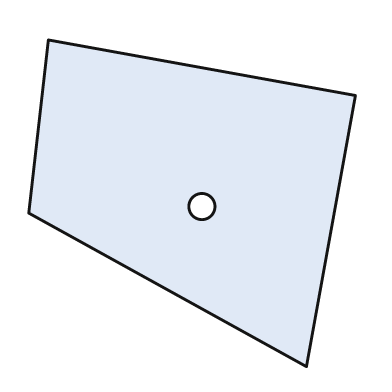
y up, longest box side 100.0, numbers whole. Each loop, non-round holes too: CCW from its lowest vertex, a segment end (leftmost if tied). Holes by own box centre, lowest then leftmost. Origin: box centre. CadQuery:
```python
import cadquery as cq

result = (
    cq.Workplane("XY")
    .moveTo(35.0, -50.0)
    .lineTo(50.0, 33.0)
    .lineTo(-44.0, 50.0)
    .lineTo(-50.0, -3.0)
    .close()
    .moveTo(3.0, -1.0)
    .circle(4.0)
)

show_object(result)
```